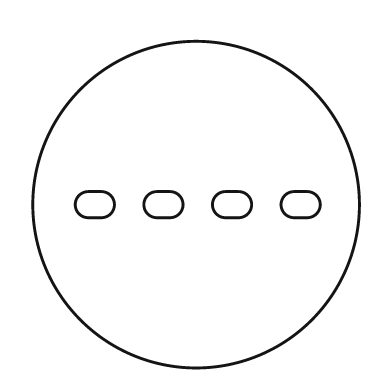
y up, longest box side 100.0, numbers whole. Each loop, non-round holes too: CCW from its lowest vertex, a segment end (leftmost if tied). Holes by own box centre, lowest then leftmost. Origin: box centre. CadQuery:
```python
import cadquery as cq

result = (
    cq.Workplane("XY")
    .moveTo(0.0, 0.0)
    .circle(50.0)
    .moveTo(-33.0, -4.0)
    .lineTo(-29.0, -4.0)
    .threePointArc((-25.0, 0.0), (-29.0, 4.0))
    .lineTo(-33.0, 4.0)
    .threePointArc((-37.0, 0.0), (-33.0, -4.0))
    .close()
    .moveTo(-12.0, -4.0)
    .lineTo(-8.0, -4.0)
    .threePointArc((-4.0, 0.0), (-8.0, 4.0))
    .lineTo(-12.0, 4.0)
    .threePointArc((-16.0, 0.0), (-12.0, -4.0))
    .close()
    .moveTo(9.0, -4.0)
    .lineTo(13.0, -4.0)
    .threePointArc((17.0, 0.0), (13.0, 4.0))
    .lineTo(9.0, 4.0)
    .threePointArc((5.0, 0.0), (9.0, -4.0))
    .close()
    .moveTo(30.0, -4.0)
    .lineTo(34.0, -4.0)
    .threePointArc((38.0, 0.0), (34.0, 4.0))
    .lineTo(30.0, 4.0)
    .threePointArc((26.0, 0.0), (30.0, -4.0))
    .close()
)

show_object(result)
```